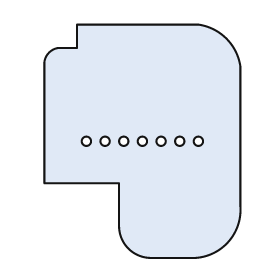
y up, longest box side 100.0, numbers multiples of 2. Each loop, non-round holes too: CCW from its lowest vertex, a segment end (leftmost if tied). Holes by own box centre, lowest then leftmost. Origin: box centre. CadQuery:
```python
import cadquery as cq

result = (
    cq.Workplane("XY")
    .moveTo(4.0, -50.0)
    .lineTo(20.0, -50.0)
    .threePointArc((36.0, -44.0), (42.0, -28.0))
    .lineTo(42.0, 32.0)
    .threePointArc((36.0, 44.0), (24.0, 50.0))
    .lineTo(-28.0, 50.0)
    .lineTo(-28.0, 40.0)
    .lineTo(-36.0, 40.0)
    .threePointArc((-40.0, 38.0), (-42.0, 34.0))
    .lineTo(-42.0, -18.0)
    .lineTo(-10.0, -18.0)
    .lineTo(-10.0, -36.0)
    .threePointArc((-6.0, -46.0), (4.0, -50.0))
    .close()
    .moveTo(-24.0, 0.0)
    .circle(2.0)
    .moveTo(-16.0, 0.0)
    .circle(2.0)
    .moveTo(-8.0, 0.0)
    .circle(2.0)
    .moveTo(0.0, 0.0)
    .circle(2.0)
    .moveTo(8.0, 0.0)
    .circle(2.0)
    .moveTo(16.0, 0.0)
    .circle(2.0)
    .moveTo(24.0, 0.0)
    .circle(2.0)
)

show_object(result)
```